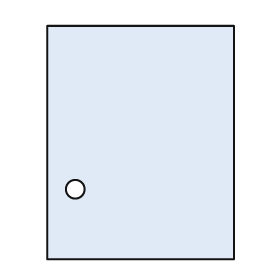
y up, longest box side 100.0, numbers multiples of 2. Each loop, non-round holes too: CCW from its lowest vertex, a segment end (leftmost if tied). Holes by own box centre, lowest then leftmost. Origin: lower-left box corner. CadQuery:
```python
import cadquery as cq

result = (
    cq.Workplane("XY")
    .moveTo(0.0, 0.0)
    .lineTo(80.0, 0.0)
    .lineTo(80.0, 100.0)
    .lineTo(0.0, 100.0)
    .close()
    .moveTo(12.0, 30.0)
    .circle(4.0)
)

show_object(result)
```